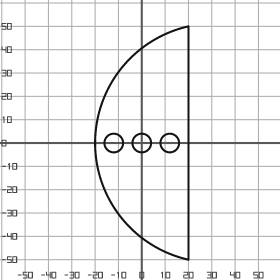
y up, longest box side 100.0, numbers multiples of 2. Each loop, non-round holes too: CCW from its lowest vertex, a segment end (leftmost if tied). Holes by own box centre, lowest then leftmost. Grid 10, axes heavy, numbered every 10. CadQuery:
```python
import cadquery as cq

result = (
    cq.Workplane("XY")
    .moveTo(20.0, -50.0)
    .lineTo(20.0, 50.0)
    .threePointArc((-20.0, 0.0), (20.0, -50.0))
    .close()
    .moveTo(-12.0, 0.0)
    .circle(4.0)
    .moveTo(0.0, 0.0)
    .circle(4.0)
    .moveTo(12.0, 0.0)
    .circle(4.0)
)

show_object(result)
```